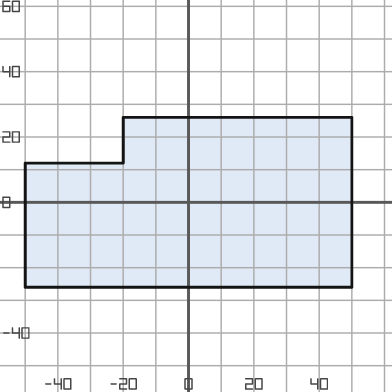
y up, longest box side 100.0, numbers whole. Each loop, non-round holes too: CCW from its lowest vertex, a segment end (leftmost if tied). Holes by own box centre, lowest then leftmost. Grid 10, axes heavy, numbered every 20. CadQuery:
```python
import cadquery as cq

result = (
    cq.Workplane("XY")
    .moveTo(-50.0, -26.0)
    .lineTo(50.0, -26.0)
    .lineTo(50.0, 26.0)
    .lineTo(-20.0, 26.0)
    .lineTo(-20.0, 12.0)
    .lineTo(-50.0, 12.0)
    .close()
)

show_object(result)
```